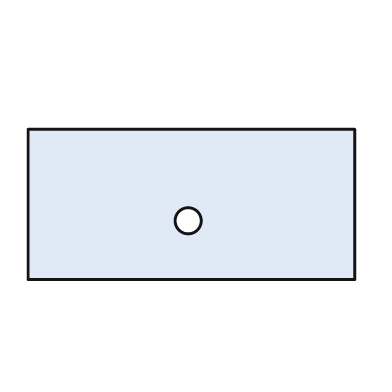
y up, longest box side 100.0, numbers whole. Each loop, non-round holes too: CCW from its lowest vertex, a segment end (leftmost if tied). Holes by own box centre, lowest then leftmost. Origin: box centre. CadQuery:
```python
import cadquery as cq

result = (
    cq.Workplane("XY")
    .moveTo(-50.0, -23.0)
    .lineTo(50.0, -23.0)
    .lineTo(50.0, 23.0)
    .lineTo(-50.0, 23.0)
    .close()
    .moveTo(-1.0, -5.0)
    .circle(4.0)
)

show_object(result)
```